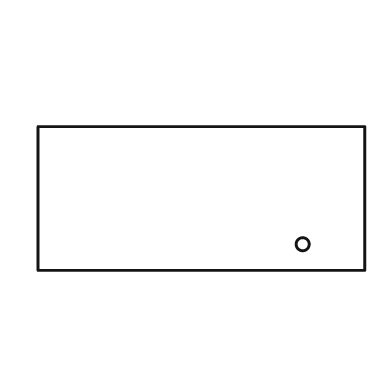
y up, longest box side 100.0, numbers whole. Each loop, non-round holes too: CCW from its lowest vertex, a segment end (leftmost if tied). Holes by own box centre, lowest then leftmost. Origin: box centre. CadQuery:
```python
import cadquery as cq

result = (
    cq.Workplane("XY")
    .moveTo(-50.0, -22.0)
    .lineTo(50.0, -22.0)
    .lineTo(50.0, 22.0)
    .lineTo(-50.0, 22.0)
    .close()
    .moveTo(31.0, -14.0)
    .circle(2.0)
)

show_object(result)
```